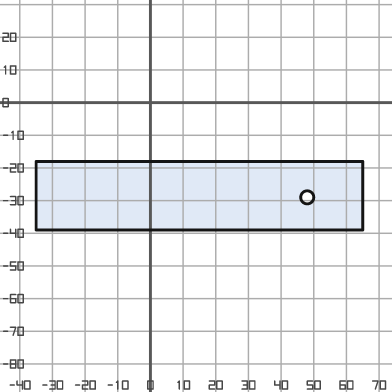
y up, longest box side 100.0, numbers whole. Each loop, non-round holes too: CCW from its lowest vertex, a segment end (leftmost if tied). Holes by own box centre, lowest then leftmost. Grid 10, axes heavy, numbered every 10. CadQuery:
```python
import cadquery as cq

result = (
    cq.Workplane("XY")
    .moveTo(-35.0, -39.0)
    .lineTo(65.0, -39.0)
    .lineTo(65.0, -18.0)
    .lineTo(-35.0, -18.0)
    .close()
    .moveTo(48.0, -29.0)
    .circle(2.0)
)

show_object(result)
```